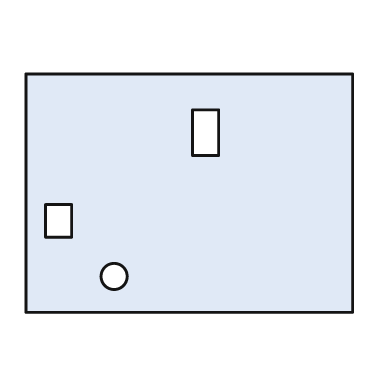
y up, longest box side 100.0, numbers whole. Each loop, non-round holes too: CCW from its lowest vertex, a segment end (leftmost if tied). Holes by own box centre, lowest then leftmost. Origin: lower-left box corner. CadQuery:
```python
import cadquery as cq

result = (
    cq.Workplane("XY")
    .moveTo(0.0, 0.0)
    .lineTo(100.0, 0.0)
    .lineTo(100.0, 73.0)
    .lineTo(0.0, 73.0)
    .close()
    .moveTo(27.0, 11.0)
    .circle(4.0)
    .moveTo(6.0, 23.0)
    .lineTo(14.0, 23.0)
    .lineTo(14.0, 33.0)
    .lineTo(6.0, 33.0)
    .close()
    .moveTo(51.0, 48.0)
    .lineTo(59.0, 48.0)
    .lineTo(59.0, 62.0)
    .lineTo(51.0, 62.0)
    .close()
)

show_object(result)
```